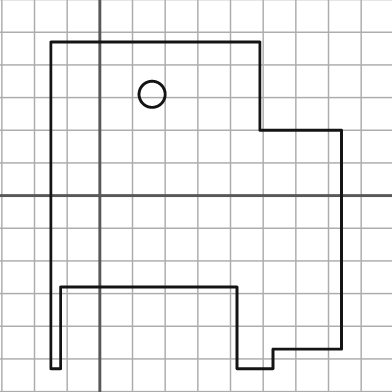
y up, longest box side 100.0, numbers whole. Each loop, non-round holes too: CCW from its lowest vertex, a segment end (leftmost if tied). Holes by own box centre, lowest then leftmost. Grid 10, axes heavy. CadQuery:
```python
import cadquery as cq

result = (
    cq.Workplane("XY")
    .moveTo(-15.0, -53.0)
    .lineTo(-12.0, -53.0)
    .lineTo(-12.0, -28.0)
    .lineTo(42.0, -28.0)
    .lineTo(42.0, -53.0)
    .lineTo(53.0, -53.0)
    .lineTo(53.0, -47.0)
    .lineTo(74.0, -47.0)
    .lineTo(74.0, 20.0)
    .lineTo(49.0, 20.0)
    .lineTo(49.0, 47.0)
    .lineTo(-15.0, 47.0)
    .close()
    .moveTo(16.0, 31.0)
    .circle(4.0)
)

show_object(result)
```